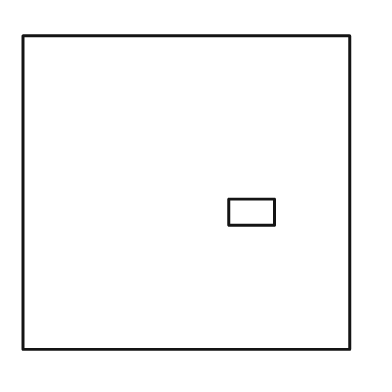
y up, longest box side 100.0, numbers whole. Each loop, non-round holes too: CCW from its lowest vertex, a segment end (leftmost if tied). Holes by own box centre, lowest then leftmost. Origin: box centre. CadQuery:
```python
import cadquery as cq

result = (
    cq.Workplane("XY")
    .moveTo(-50.0, -48.0)
    .lineTo(50.0, -48.0)
    .lineTo(50.0, 48.0)
    .lineTo(-50.0, 48.0)
    .close()
    .moveTo(13.0, -10.0)
    .lineTo(27.0, -10.0)
    .lineTo(27.0, -2.0)
    .lineTo(13.0, -2.0)
    .close()
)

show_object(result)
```